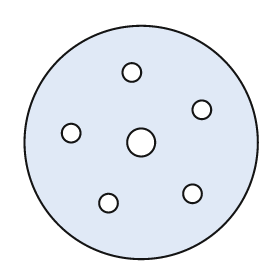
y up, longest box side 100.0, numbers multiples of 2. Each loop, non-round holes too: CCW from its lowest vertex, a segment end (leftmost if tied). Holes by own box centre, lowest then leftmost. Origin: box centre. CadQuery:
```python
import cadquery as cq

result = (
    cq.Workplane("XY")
    .moveTo(0.0, 0.0)
    .circle(50.0)
    .moveTo(-14.0, -26.0)
    .circle(4.0)
    .moveTo(22.0, -22.0)
    .circle(4.0)
    .moveTo(0.0, 0.0)
    .circle(6.0)
    .moveTo(-30.0, 4.0)
    .circle(4.0)
    .moveTo(26.0, 14.0)
    .circle(4.0)
    .moveTo(-4.0, 30.0)
    .circle(4.0)
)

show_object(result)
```